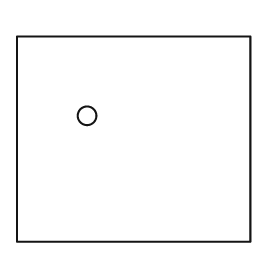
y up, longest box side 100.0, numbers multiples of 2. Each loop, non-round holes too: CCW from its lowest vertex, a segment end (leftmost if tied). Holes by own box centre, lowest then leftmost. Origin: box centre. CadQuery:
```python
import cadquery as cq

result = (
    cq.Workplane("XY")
    .moveTo(-50.0, -44.0)
    .lineTo(50.0, -44.0)
    .lineTo(50.0, 44.0)
    .lineTo(-50.0, 44.0)
    .close()
    .moveTo(-20.0, 10.0)
    .circle(4.0)
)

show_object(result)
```